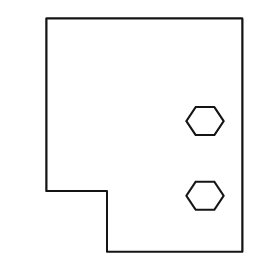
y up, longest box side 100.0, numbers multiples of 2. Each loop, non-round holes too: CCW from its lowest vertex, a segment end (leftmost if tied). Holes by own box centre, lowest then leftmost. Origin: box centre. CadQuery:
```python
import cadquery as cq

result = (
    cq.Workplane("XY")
    .moveTo(-16.0, -50.0)
    .lineTo(42.0, -50.0)
    .lineTo(42.0, 50.0)
    .lineTo(-42.0, 50.0)
    .lineTo(-42.0, -24.0)
    .lineTo(-16.0, -24.0)
    .close()
    .moveTo(22.0, -32.0)
    .lineTo(30.0, -32.0)
    .lineTo(34.0, -26.0)
    .lineTo(30.0, -20.0)
    .lineTo(22.0, -20.0)
    .lineTo(18.0, -26.0)
    .close()
    .moveTo(22.0, 0.0)
    .lineTo(30.0, 0.0)
    .lineTo(34.0, 6.0)
    .lineTo(30.0, 12.0)
    .lineTo(22.0, 12.0)
    .lineTo(18.0, 6.0)
    .close()
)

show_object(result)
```